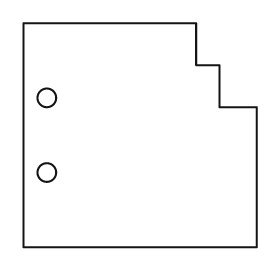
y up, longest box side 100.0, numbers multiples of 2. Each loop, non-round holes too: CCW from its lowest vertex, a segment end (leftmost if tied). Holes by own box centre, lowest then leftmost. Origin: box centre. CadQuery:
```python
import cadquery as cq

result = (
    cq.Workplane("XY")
    .moveTo(-50.0, -48.0)
    .lineTo(50.0, -48.0)
    .lineTo(50.0, 12.0)
    .lineTo(34.0, 12.0)
    .lineTo(34.0, 30.0)
    .lineTo(24.0, 30.0)
    .lineTo(24.0, 48.0)
    .lineTo(-50.0, 48.0)
    .close()
    .moveTo(-40.0, -16.0)
    .circle(4.0)
    .moveTo(-40.0, 16.0)
    .circle(4.0)
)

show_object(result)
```